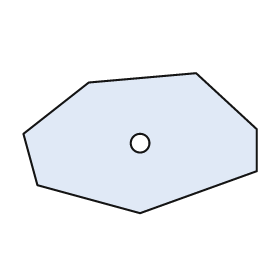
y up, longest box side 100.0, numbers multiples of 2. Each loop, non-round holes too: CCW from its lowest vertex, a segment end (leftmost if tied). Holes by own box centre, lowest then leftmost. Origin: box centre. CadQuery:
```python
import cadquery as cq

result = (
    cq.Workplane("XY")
    .moveTo(0.0, -30.0)
    .lineTo(50.0, -12.0)
    .lineTo(50.0, 6.0)
    .lineTo(24.0, 30.0)
    .lineTo(-22.0, 26.0)
    .lineTo(-50.0, 4.0)
    .lineTo(-44.0, -18.0)
    .close()
    .moveTo(0.0, 0.0)
    .circle(4.0)
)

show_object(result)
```